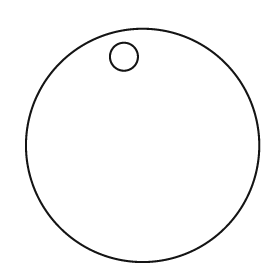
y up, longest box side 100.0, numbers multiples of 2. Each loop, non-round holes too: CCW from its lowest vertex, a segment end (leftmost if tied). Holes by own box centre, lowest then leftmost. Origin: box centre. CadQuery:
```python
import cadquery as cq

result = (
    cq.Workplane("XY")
    .moveTo(0.0, 0.0)
    .circle(50.0)
    .moveTo(-8.0, 38.0)
    .circle(6.0)
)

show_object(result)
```